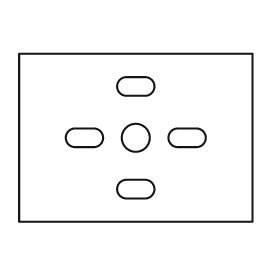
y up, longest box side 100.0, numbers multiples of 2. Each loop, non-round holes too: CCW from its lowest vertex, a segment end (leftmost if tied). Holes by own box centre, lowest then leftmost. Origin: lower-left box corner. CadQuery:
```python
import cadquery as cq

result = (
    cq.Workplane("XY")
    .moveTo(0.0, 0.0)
    .lineTo(100.0, 0.0)
    .lineTo(100.0, 72.0)
    .lineTo(0.0, 72.0)
    .close()
    .moveTo(46.0, 10.0)
    .lineTo(54.0, 10.0)
    .threePointArc((58.0, 14.0), (54.0, 18.0))
    .lineTo(46.0, 18.0)
    .threePointArc((42.0, 14.0), (46.0, 10.0))
    .close()
    .moveTo(24.0, 32.0)
    .lineTo(32.0, 32.0)
    .threePointArc((36.0, 36.0), (32.0, 40.0))
    .lineTo(24.0, 40.0)
    .threePointArc((20.0, 36.0), (24.0, 32.0))
    .close()
    .moveTo(50.0, 36.0)
    .circle(6.0)
    .moveTo(68.0, 32.0)
    .lineTo(76.0, 32.0)
    .threePointArc((80.0, 36.0), (76.0, 40.0))
    .lineTo(68.0, 40.0)
    .threePointArc((64.0, 36.0), (68.0, 32.0))
    .close()
    .moveTo(46.0, 54.0)
    .lineTo(54.0, 54.0)
    .threePointArc((58.0, 58.0), (54.0, 62.0))
    .lineTo(46.0, 62.0)
    .threePointArc((42.0, 58.0), (46.0, 54.0))
    .close()
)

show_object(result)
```